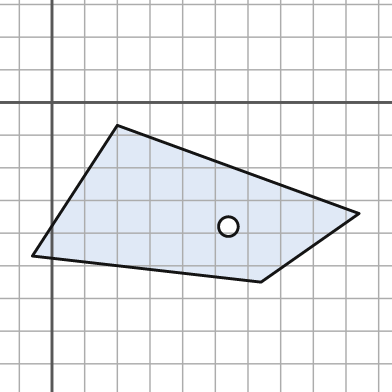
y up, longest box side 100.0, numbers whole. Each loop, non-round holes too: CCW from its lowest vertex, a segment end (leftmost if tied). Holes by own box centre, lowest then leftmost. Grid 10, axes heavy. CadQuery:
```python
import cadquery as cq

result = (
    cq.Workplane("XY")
    .moveTo(64.0, -55.0)
    .lineTo(94.0, -34.0)
    .lineTo(20.0, -7.0)
    .lineTo(-6.0, -47.0)
    .close()
    .moveTo(54.0, -38.0)
    .circle(3.0)
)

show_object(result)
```